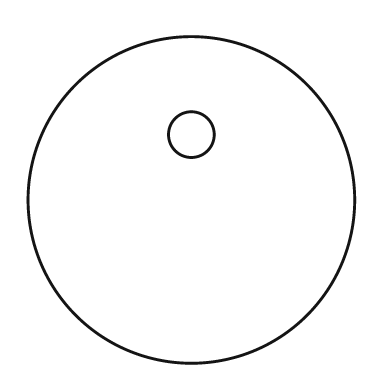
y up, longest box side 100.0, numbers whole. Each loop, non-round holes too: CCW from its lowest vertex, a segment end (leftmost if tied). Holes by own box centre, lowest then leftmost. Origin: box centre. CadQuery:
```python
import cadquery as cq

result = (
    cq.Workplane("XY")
    .moveTo(0.0, 0.0)
    .circle(50.0)
    .moveTo(0.0, 20.0)
    .circle(7.0)
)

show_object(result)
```